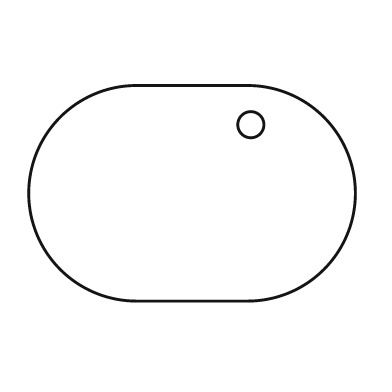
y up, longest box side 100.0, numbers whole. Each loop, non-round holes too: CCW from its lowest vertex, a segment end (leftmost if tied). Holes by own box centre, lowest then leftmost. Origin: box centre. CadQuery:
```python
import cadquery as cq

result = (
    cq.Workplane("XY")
    .moveTo(-17.0, -33.0)
    .lineTo(17.0, -33.0)
    .threePointArc((50.0, 0.0), (17.0, 33.0))
    .lineTo(-17.0, 33.0)
    .threePointArc((-50.0, 0.0), (-17.0, -33.0))
    .close()
    .moveTo(18.0, 21.0)
    .circle(4.0)
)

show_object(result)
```